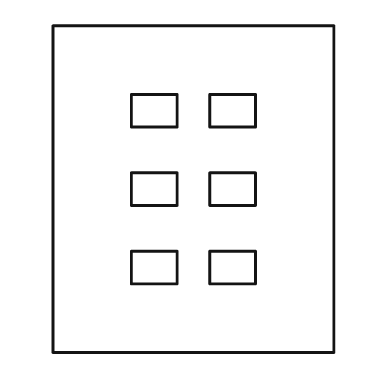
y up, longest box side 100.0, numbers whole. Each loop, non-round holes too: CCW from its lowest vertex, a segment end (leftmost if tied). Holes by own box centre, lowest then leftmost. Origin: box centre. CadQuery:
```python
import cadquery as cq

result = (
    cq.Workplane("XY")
    .moveTo(-43.0, -50.0)
    .lineTo(43.0, -50.0)
    .lineTo(43.0, 50.0)
    .lineTo(-43.0, 50.0)
    .close()
    .moveTo(-19.0, -29.0)
    .lineTo(-5.0, -29.0)
    .lineTo(-5.0, -19.0)
    .lineTo(-19.0, -19.0)
    .close()
    .moveTo(5.0, -29.0)
    .lineTo(19.0, -29.0)
    .lineTo(19.0, -19.0)
    .lineTo(5.0, -19.0)
    .close()
    .moveTo(-19.0, -5.0)
    .lineTo(-5.0, -5.0)
    .lineTo(-5.0, 5.0)
    .lineTo(-19.0, 5.0)
    .close()
    .moveTo(5.0, -5.0)
    .lineTo(19.0, -5.0)
    .lineTo(19.0, 5.0)
    .lineTo(5.0, 5.0)
    .close()
    .moveTo(-19.0, 19.0)
    .lineTo(-5.0, 19.0)
    .lineTo(-5.0, 29.0)
    .lineTo(-19.0, 29.0)
    .close()
    .moveTo(5.0, 19.0)
    .lineTo(19.0, 19.0)
    .lineTo(19.0, 29.0)
    .lineTo(5.0, 29.0)
    .close()
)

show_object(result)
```